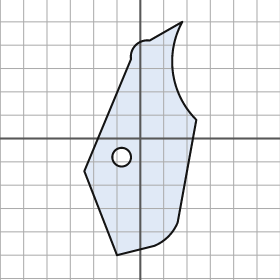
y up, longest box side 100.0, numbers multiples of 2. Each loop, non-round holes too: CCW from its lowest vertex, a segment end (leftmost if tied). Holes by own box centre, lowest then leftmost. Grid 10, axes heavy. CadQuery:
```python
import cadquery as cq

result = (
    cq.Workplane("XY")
    .moveTo(-10.0, -50.0)
    .lineTo(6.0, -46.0)
    .threePointArc((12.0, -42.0), (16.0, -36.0))
    .lineTo(24.0, 8.0)
    .threePointArc((14.0, 28.0), (18.0, 50.0))
    .lineTo(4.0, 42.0)
    .threePointArc((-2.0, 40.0), (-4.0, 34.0))
    .lineTo(-24.0, -14.0)
    .close()
    .moveTo(-8.0, -8.0)
    .circle(4.0)
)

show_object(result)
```